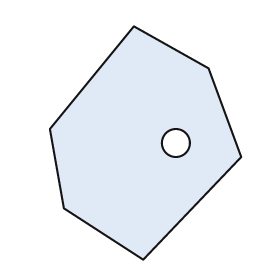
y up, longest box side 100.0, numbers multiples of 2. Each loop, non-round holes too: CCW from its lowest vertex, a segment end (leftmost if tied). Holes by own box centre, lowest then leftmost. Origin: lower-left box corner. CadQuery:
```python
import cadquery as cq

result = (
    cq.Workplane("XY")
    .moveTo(40.0, 0.0)
    .lineTo(82.0, 44.0)
    .lineTo(68.0, 82.0)
    .lineTo(36.0, 100.0)
    .lineTo(0.0, 56.0)
    .lineTo(6.0, 22.0)
    .close()
    .moveTo(54.0, 50.0)
    .circle(6.0)
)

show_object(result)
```